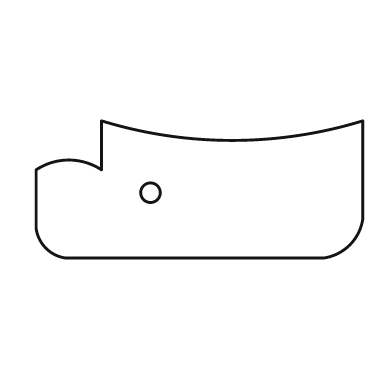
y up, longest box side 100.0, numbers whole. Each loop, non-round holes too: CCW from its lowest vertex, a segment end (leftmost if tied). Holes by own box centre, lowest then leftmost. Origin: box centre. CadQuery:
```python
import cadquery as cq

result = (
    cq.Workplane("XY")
    .moveTo(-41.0, -21.0)
    .lineTo(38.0, -21.0)
    .threePointArc((46.0, -17.0), (50.0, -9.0))
    .lineTo(50.0, 21.0)
    .threePointArc((10.0, 15.0), (-30.0, 21.0))
    .lineTo(-30.0, 6.0)
    .threePointArc((-40.0, 9.0), (-50.0, 6.0))
    .lineTo(-50.0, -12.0)
    .threePointArc((-47.0, -18.0), (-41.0, -21.0))
    .close()
    .moveTo(-15.0, -1.0)
    .circle(3.0)
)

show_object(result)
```